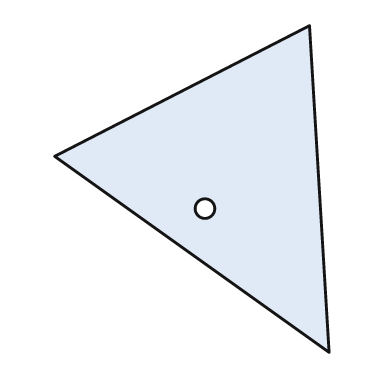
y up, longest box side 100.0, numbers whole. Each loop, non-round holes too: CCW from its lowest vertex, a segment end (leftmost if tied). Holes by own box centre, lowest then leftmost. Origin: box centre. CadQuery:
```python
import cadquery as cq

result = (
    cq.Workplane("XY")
    .moveTo(42.0, -50.0)
    .lineTo(36.0, 50.0)
    .lineTo(-42.0, 10.0)
    .close()
    .moveTo(4.0, -6.0)
    .circle(3.0)
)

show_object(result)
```